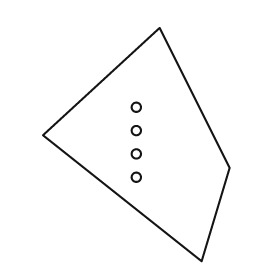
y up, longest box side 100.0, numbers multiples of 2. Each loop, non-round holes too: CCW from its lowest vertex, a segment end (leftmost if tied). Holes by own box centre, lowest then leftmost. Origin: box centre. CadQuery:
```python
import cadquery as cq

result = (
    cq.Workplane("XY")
    .moveTo(28.0, -50.0)
    .lineTo(40.0, -10.0)
    .lineTo(10.0, 50.0)
    .lineTo(-40.0, 4.0)
    .close()
    .moveTo(0.0, -14.0)
    .circle(2.0)
    .moveTo(0.0, -4.0)
    .circle(2.0)
    .moveTo(0.0, 6.0)
    .circle(2.0)
    .moveTo(0.0, 16.0)
    .circle(2.0)
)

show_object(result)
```